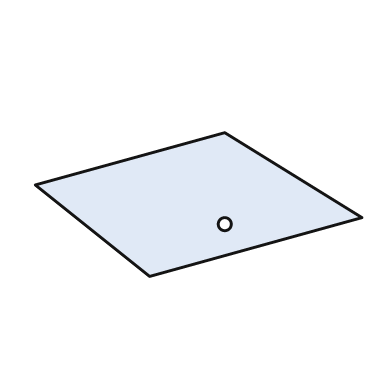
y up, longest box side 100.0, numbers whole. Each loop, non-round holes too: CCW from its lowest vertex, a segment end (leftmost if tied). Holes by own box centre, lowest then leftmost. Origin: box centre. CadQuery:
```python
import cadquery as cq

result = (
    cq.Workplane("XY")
    .moveTo(-15.0, -22.0)
    .lineTo(50.0, -4.0)
    .lineTo(8.0, 22.0)
    .lineTo(-50.0, 6.0)
    .close()
    .moveTo(8.0, -6.0)
    .circle(2.0)
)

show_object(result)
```